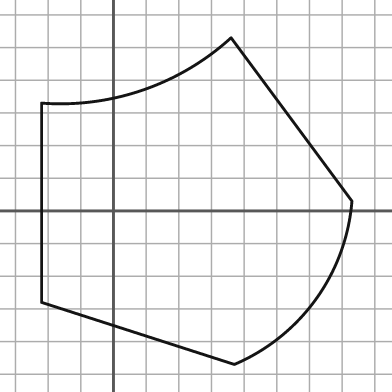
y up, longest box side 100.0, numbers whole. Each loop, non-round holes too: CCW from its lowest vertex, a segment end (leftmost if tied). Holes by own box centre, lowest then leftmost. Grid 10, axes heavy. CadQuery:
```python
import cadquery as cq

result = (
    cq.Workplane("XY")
    .moveTo(37.0, -47.0)
    .threePointArc((62.0, -27.0), (73.0, 3.0))
    .lineTo(36.0, 53.0)
    .threePointArc((9.0, 37.0), (-22.0, 33.0))
    .lineTo(-22.0, -28.0)
    .close()
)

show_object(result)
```